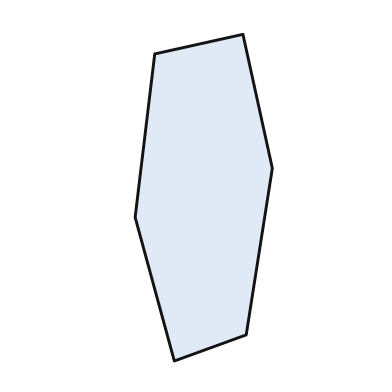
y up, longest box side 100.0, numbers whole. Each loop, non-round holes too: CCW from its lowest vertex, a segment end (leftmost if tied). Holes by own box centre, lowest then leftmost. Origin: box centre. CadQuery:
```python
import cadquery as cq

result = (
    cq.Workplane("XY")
    .moveTo(-9.0, -50.0)
    .lineTo(13.0, -42.0)
    .lineTo(21.0, 9.0)
    .lineTo(12.0, 50.0)
    .lineTo(-15.0, 44.0)
    .lineTo(-21.0, -6.0)
    .close()
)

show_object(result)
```